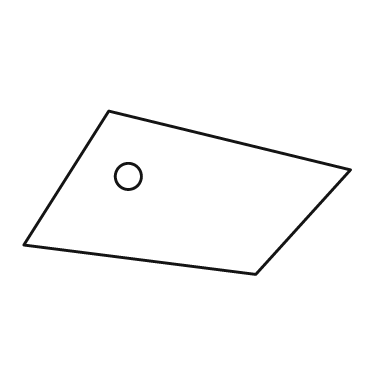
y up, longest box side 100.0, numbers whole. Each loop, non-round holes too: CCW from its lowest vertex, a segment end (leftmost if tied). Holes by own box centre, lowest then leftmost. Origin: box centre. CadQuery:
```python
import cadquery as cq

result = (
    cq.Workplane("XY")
    .moveTo(21.0, -25.0)
    .lineTo(50.0, 7.0)
    .lineTo(-24.0, 25.0)
    .lineTo(-50.0, -16.0)
    .close()
    .moveTo(-18.0, 5.0)
    .circle(4.0)
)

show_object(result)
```